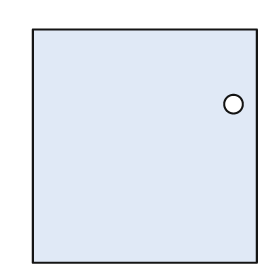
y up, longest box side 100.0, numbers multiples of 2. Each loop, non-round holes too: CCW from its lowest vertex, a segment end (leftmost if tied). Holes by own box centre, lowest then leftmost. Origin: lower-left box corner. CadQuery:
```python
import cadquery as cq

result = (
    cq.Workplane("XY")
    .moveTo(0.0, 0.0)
    .lineTo(96.0, 0.0)
    .lineTo(96.0, 100.0)
    .lineTo(0.0, 100.0)
    .close()
    .moveTo(86.0, 68.0)
    .circle(4.0)
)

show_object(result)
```